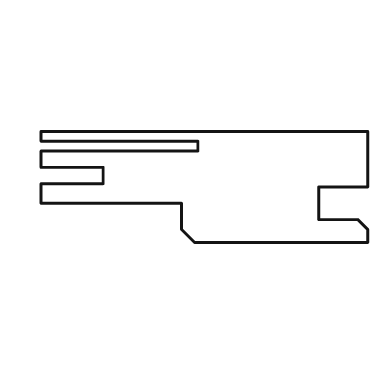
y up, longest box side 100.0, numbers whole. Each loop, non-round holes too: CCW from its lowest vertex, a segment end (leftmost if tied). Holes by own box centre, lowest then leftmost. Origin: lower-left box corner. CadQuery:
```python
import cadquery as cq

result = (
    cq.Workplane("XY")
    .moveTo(47.0, 0.0)
    .lineTo(100.0, 0.0)
    .lineTo(100.0, 4.0)
    .lineTo(97.0, 7.0)
    .lineTo(85.0, 7.0)
    .lineTo(85.0, 17.0)
    .lineTo(100.0, 17.0)
    .lineTo(100.0, 34.0)
    .lineTo(0.0, 34.0)
    .lineTo(0.0, 31.0)
    .lineTo(48.0, 31.0)
    .lineTo(48.0, 28.0)
    .lineTo(0.0, 28.0)
    .lineTo(0.0, 23.0)
    .lineTo(19.0, 23.0)
    .lineTo(19.0, 18.0)
    .lineTo(0.0, 18.0)
    .lineTo(0.0, 12.0)
    .lineTo(43.0, 12.0)
    .lineTo(43.0, 4.0)
    .close()
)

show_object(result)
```